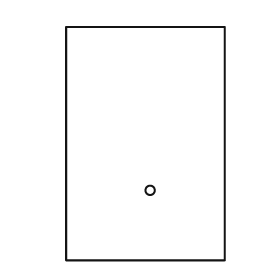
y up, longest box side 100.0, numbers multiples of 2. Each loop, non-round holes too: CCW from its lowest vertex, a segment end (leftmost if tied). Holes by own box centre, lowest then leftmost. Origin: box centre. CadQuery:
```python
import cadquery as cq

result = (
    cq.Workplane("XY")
    .moveTo(-34.0, -50.0)
    .lineTo(34.0, -50.0)
    .lineTo(34.0, 50.0)
    .lineTo(-34.0, 50.0)
    .close()
    .moveTo(2.0, -20.0)
    .circle(2.0)
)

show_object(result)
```